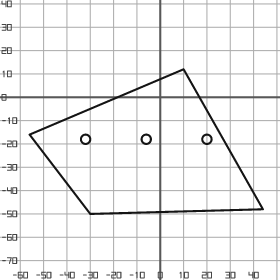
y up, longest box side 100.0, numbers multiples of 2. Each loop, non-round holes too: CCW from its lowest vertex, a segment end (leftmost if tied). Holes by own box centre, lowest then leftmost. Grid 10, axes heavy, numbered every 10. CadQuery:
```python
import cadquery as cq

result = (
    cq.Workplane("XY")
    .moveTo(-30.0, -50.0)
    .lineTo(44.0, -48.0)
    .lineTo(10.0, 12.0)
    .lineTo(-56.0, -16.0)
    .close()
    .moveTo(-32.0, -18.0)
    .circle(2.0)
    .moveTo(-6.0, -18.0)
    .circle(2.0)
    .moveTo(20.0, -18.0)
    .circle(2.0)
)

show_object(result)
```